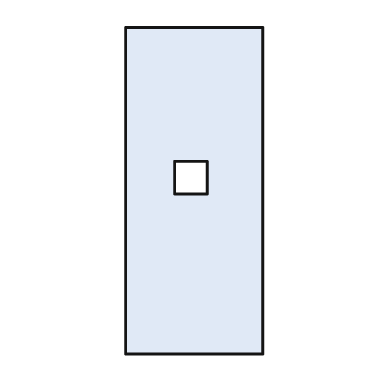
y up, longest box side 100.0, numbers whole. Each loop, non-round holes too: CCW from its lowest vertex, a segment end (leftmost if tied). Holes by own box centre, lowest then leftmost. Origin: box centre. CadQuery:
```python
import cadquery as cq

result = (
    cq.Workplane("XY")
    .moveTo(-21.0, -50.0)
    .lineTo(21.0, -50.0)
    .lineTo(21.0, 50.0)
    .lineTo(-21.0, 50.0)
    .close()
    .moveTo(-6.0, -1.0)
    .lineTo(4.0, -1.0)
    .lineTo(4.0, 9.0)
    .lineTo(-6.0, 9.0)
    .close()
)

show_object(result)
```